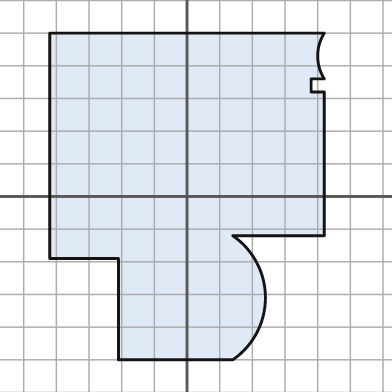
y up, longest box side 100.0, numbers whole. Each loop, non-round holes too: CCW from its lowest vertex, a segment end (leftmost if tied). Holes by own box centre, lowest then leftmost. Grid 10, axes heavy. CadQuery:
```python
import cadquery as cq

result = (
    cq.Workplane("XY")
    .moveTo(-21.0, -50.0)
    .lineTo(14.0, -50.0)
    .threePointArc((24.0, -31.0), (14.0, -12.0))
    .lineTo(42.0, -12.0)
    .lineTo(42.0, 32.0)
    .lineTo(38.0, 32.0)
    .lineTo(38.0, 36.0)
    .lineTo(42.0, 36.0)
    .threePointArc((40.0, 43.0), (42.0, 50.0))
    .lineTo(-42.0, 50.0)
    .lineTo(-42.0, -19.0)
    .lineTo(-21.0, -19.0)
    .close()
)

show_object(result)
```